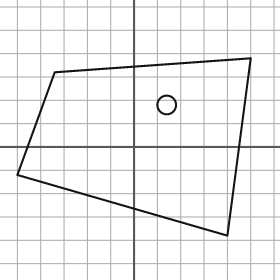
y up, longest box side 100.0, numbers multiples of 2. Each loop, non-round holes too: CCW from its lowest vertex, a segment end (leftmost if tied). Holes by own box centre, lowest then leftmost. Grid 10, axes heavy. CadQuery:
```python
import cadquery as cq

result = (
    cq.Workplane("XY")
    .moveTo(40.0, -38.0)
    .lineTo(50.0, 38.0)
    .lineTo(-34.0, 32.0)
    .lineTo(-50.0, -12.0)
    .close()
    .moveTo(14.0, 18.0)
    .circle(4.0)
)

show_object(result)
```